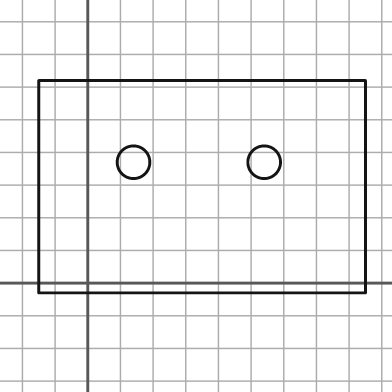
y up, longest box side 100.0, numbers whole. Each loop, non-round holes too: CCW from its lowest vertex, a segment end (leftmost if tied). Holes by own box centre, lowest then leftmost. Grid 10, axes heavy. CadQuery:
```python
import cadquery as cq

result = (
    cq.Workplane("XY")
    .moveTo(-15.0, -3.0)
    .lineTo(85.0, -3.0)
    .lineTo(85.0, 62.0)
    .lineTo(-15.0, 62.0)
    .close()
    .moveTo(14.0, 37.0)
    .circle(5.0)
    .moveTo(54.0, 37.0)
    .circle(5.0)
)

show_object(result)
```